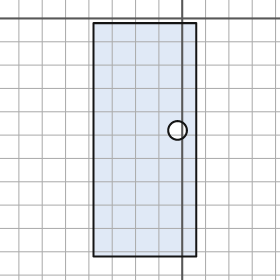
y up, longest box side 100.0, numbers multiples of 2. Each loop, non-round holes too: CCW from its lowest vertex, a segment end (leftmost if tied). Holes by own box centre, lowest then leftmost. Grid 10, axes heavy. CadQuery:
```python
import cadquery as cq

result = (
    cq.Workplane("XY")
    .moveTo(-38.0, -102.0)
    .lineTo(6.0, -102.0)
    .lineTo(6.0, -2.0)
    .lineTo(-38.0, -2.0)
    .close()
    .moveTo(-2.0, -48.0)
    .circle(4.0)
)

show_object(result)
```